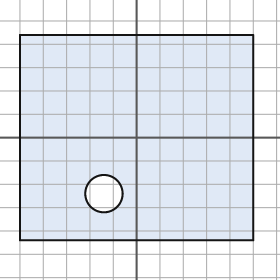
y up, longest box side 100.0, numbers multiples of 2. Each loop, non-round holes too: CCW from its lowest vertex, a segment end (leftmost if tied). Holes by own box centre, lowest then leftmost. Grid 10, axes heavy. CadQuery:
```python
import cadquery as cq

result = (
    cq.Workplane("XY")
    .moveTo(-50.0, -44.0)
    .lineTo(50.0, -44.0)
    .lineTo(50.0, 44.0)
    .lineTo(-50.0, 44.0)
    .close()
    .moveTo(-14.0, -24.0)
    .circle(8.0)
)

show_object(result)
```